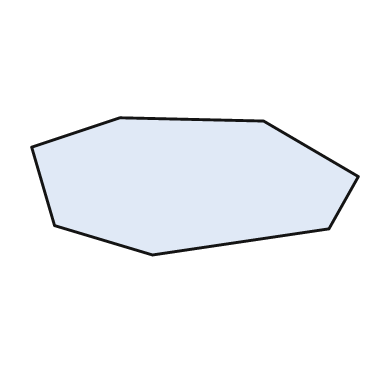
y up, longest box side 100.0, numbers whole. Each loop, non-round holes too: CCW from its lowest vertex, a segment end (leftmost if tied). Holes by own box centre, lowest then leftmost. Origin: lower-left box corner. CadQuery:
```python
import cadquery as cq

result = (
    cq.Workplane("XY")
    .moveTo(37.0, 0.0)
    .lineTo(91.0, 8.0)
    .lineTo(100.0, 24.0)
    .lineTo(71.0, 41.0)
    .lineTo(27.0, 42.0)
    .lineTo(0.0, 33.0)
    .lineTo(7.0, 9.0)
    .close()
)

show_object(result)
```